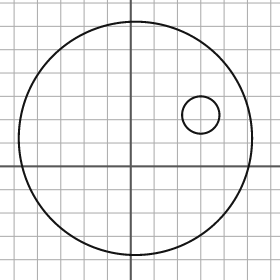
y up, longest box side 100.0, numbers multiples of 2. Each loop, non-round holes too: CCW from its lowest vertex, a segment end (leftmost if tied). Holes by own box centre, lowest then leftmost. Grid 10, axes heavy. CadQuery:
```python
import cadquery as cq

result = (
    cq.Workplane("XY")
    .moveTo(2.0, 12.0)
    .circle(50.0)
    .moveTo(30.0, 22.0)
    .circle(8.0)
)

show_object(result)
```